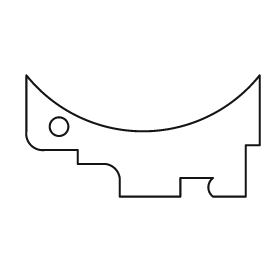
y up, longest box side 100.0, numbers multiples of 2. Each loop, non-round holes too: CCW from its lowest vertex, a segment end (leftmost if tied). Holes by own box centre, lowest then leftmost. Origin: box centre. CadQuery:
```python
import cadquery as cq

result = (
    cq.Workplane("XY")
    .moveTo(-10.0, -26.0)
    .lineTo(16.0, -26.0)
    .lineTo(16.0, -18.0)
    .lineTo(30.0, -18.0)
    .threePointArc((28.0, -22.0), (30.0, -26.0))
    .lineTo(44.0, -26.0)
    .lineTo(44.0, -4.0)
    .lineTo(50.0, -4.0)
    .lineTo(50.0, 26.0)
    .threePointArc((0.0, 2.0), (-50.0, 26.0))
    .lineTo(-50.0, 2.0)
    .threePointArc((-48.0, -4.0), (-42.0, -6.0))
    .lineTo(-28.0, -6.0)
    .lineTo(-28.0, -12.0)
    .lineTo(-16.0, -12.0)
    .threePointArc((-12.0, -14.0), (-10.0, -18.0))
    .close()
    .moveTo(-36.0, 4.0)
    .circle(4.0)
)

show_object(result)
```